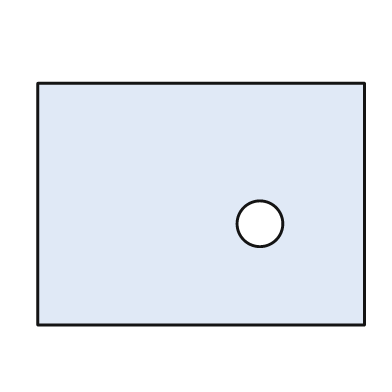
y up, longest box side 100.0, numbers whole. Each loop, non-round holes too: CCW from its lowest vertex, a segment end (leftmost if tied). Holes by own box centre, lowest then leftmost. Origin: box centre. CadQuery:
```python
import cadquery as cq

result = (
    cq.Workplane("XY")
    .moveTo(-50.0, -37.0)
    .lineTo(50.0, -37.0)
    .lineTo(50.0, 37.0)
    .lineTo(-50.0, 37.0)
    .close()
    .moveTo(18.0, -6.0)
    .circle(7.0)
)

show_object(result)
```